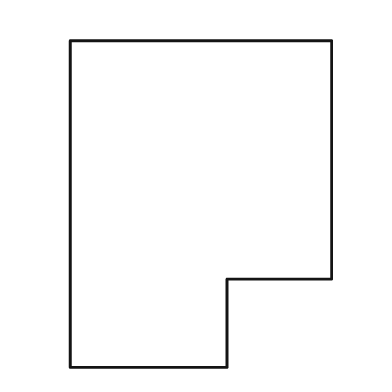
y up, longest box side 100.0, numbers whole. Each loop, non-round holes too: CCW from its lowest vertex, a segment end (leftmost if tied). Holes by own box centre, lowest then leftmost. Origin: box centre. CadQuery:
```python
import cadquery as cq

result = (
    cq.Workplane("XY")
    .moveTo(-40.0, -50.0)
    .lineTo(8.0, -50.0)
    .lineTo(8.0, -23.0)
    .lineTo(40.0, -23.0)
    .lineTo(40.0, 50.0)
    .lineTo(-40.0, 50.0)
    .close()
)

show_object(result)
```